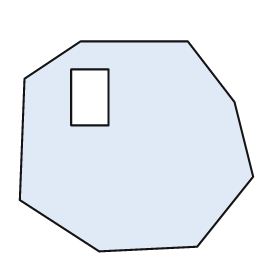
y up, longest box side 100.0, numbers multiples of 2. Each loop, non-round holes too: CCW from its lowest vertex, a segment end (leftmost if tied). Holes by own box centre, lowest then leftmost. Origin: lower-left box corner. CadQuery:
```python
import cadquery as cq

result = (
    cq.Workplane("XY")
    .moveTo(34.0, 0.0)
    .lineTo(76.0, 2.0)
    .lineTo(100.0, 32.0)
    .lineTo(92.0, 64.0)
    .lineTo(72.0, 90.0)
    .lineTo(26.0, 90.0)
    .lineTo(2.0, 74.0)
    .lineTo(0.0, 22.0)
    .close()
    .moveTo(22.0, 54.0)
    .lineTo(38.0, 54.0)
    .lineTo(38.0, 78.0)
    .lineTo(22.0, 78.0)
    .close()
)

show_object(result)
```